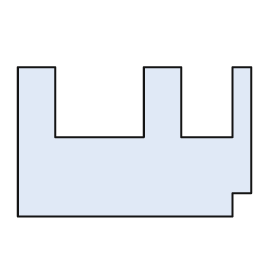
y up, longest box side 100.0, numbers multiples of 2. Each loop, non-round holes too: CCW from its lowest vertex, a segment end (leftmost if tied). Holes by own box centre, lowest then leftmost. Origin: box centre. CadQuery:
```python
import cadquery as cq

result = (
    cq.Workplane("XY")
    .moveTo(-50.0, -32.0)
    .lineTo(42.0, -32.0)
    .lineTo(42.0, -22.0)
    .lineTo(50.0, -22.0)
    .lineTo(50.0, 32.0)
    .lineTo(42.0, 32.0)
    .lineTo(42.0, 2.0)
    .lineTo(20.0, 2.0)
    .lineTo(20.0, 32.0)
    .lineTo(4.0, 32.0)
    .lineTo(4.0, 2.0)
    .lineTo(-34.0, 2.0)
    .lineTo(-34.0, 32.0)
    .lineTo(-50.0, 32.0)
    .close()
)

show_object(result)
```